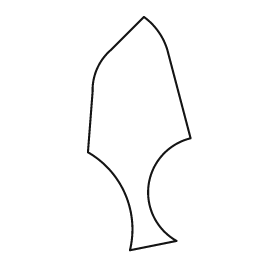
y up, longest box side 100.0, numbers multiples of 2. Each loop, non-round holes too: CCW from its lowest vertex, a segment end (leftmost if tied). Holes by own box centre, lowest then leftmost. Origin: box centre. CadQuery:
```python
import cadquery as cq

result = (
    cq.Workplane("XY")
    .moveTo(-4.0, -50.0)
    .lineTo(16.0, -46.0)
    .threePointArc((4.0, -22.0), (22.0, -2.0))
    .lineTo(12.0, 36.0)
    .threePointArc((8.0, 44.0), (2.0, 50.0))
    .lineTo(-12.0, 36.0)
    .threePointArc((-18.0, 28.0), (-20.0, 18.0))
    .lineTo(-22.0, -8.0)
    .threePointArc((-6.0, -26.0), (-4.0, -50.0))
    .close()
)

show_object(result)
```